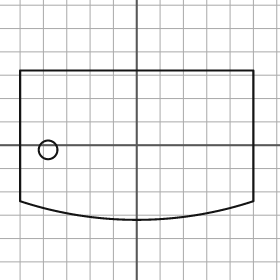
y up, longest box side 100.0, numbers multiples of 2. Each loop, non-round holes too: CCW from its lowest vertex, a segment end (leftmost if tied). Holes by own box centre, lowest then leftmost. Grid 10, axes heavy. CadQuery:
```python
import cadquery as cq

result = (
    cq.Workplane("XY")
    .moveTo(-50.0, -24.0)
    .threePointArc((0.0, -32.0), (50.0, -24.0))
    .lineTo(50.0, 32.0)
    .lineTo(-50.0, 32.0)
    .close()
    .moveTo(-38.0, -2.0)
    .circle(4.0)
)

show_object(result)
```